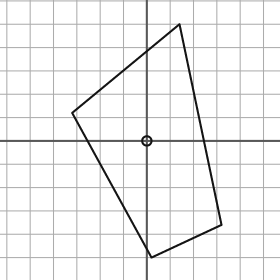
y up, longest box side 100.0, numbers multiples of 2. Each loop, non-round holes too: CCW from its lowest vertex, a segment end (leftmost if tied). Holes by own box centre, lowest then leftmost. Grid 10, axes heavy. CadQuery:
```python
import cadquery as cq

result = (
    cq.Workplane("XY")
    .moveTo(2.0, -50.0)
    .lineTo(32.0, -36.0)
    .lineTo(14.0, 50.0)
    .lineTo(-32.0, 12.0)
    .close()
    .moveTo(0.0, 0.0)
    .circle(2.0)
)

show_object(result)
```